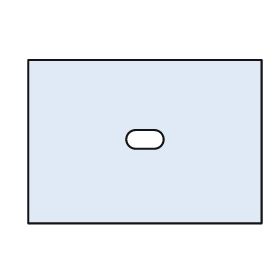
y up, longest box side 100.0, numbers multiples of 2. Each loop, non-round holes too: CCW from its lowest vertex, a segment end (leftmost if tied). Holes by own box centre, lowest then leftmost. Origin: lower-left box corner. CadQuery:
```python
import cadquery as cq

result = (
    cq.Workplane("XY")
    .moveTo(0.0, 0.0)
    .lineTo(100.0, 0.0)
    .lineTo(100.0, 70.0)
    .lineTo(0.0, 70.0)
    .close()
    .moveTo(46.0, 32.0)
    .lineTo(54.0, 32.0)
    .threePointArc((58.0, 36.0), (54.0, 40.0))
    .lineTo(46.0, 40.0)
    .threePointArc((42.0, 36.0), (46.0, 32.0))
    .close()
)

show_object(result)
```